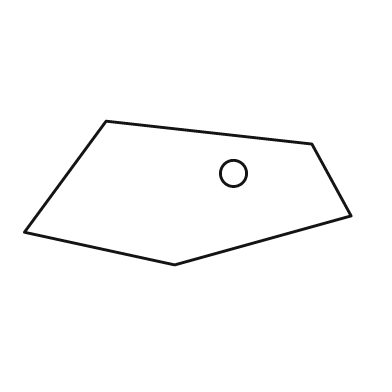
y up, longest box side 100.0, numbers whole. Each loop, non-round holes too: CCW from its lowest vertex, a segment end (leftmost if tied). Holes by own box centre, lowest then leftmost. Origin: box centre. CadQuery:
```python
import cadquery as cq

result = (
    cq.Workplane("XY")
    .moveTo(-4.0, -22.0)
    .lineTo(50.0, -7.0)
    .lineTo(38.0, 15.0)
    .lineTo(-25.0, 22.0)
    .lineTo(-50.0, -12.0)
    .close()
    .moveTo(14.0, 6.0)
    .circle(4.0)
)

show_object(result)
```